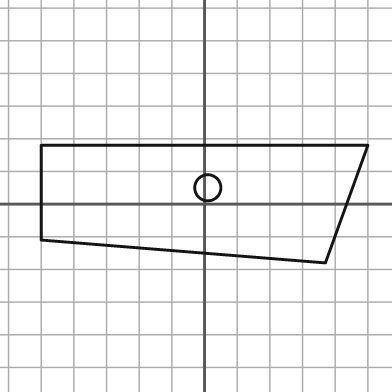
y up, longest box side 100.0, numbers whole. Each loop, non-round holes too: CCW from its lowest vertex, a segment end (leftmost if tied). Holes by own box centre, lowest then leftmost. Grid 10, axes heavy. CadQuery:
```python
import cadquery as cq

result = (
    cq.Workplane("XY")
    .moveTo(37.0, -18.0)
    .lineTo(50.0, 18.0)
    .lineTo(-50.0, 18.0)
    .lineTo(-50.0, -11.0)
    .close()
    .moveTo(1.0, 5.0)
    .circle(4.0)
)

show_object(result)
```